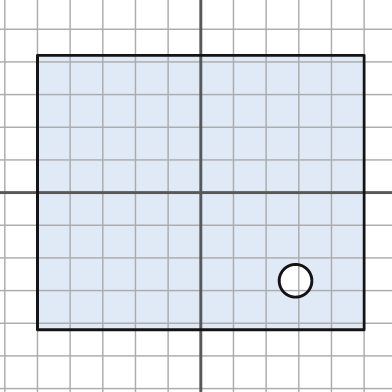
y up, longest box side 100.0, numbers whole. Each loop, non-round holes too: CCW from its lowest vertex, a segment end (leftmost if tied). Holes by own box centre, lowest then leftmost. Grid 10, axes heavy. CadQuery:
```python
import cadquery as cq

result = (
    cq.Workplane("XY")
    .moveTo(-50.0, -42.0)
    .lineTo(50.0, -42.0)
    .lineTo(50.0, 42.0)
    .lineTo(-50.0, 42.0)
    .close()
    .moveTo(29.0, -27.0)
    .circle(5.0)
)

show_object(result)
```